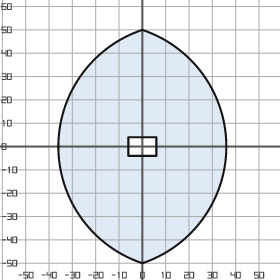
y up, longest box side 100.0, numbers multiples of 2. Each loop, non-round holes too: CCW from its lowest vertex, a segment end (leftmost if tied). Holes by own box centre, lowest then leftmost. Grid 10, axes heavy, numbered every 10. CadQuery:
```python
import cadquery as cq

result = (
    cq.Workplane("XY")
    .moveTo(0.0, -50.0)
    .threePointArc((36.0, 0.0), (0.0, 50.0))
    .threePointArc((-36.0, 0.0), (0.0, -50.0))
    .close()
    .moveTo(-6.0, -4.0)
    .lineTo(6.0, -4.0)
    .lineTo(6.0, 4.0)
    .lineTo(-6.0, 4.0)
    .close()
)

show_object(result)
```